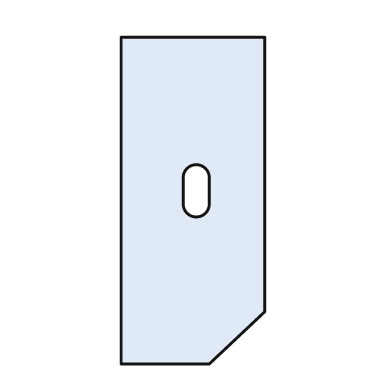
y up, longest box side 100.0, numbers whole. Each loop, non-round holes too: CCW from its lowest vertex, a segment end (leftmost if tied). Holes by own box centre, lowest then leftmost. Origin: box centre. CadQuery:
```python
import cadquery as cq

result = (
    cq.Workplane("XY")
    .moveTo(-22.0, -50.0)
    .lineTo(5.0, -50.0)
    .lineTo(22.0, -34.0)
    .lineTo(22.0, 50.0)
    .lineTo(-22.0, 50.0)
    .close()
    .moveTo(-3.0, -1.0)
    .threePointArc((1.0, -5.0), (5.0, -1.0))
    .lineTo(5.0, 7.0)
    .threePointArc((1.0, 11.0), (-3.0, 7.0))
    .close()
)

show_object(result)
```